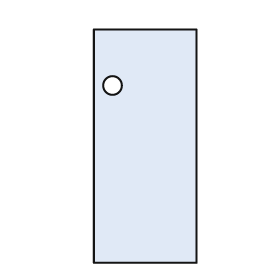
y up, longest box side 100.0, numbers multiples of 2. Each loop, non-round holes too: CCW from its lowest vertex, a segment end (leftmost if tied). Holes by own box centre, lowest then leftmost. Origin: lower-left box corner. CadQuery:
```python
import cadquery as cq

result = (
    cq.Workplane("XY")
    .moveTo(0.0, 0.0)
    .lineTo(44.0, 0.0)
    .lineTo(44.0, 100.0)
    .lineTo(0.0, 100.0)
    .close()
    .moveTo(8.0, 76.0)
    .circle(4.0)
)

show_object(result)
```